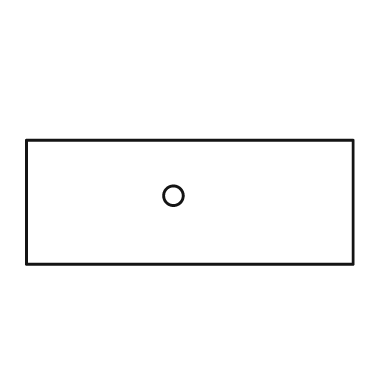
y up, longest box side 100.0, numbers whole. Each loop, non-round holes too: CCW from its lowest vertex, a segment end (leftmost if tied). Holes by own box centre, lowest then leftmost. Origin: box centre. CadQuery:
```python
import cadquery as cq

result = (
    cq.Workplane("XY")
    .moveTo(-50.0, -19.0)
    .lineTo(50.0, -19.0)
    .lineTo(50.0, 19.0)
    .lineTo(-50.0, 19.0)
    .close()
    .moveTo(-5.0, 2.0)
    .circle(3.0)
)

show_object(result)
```